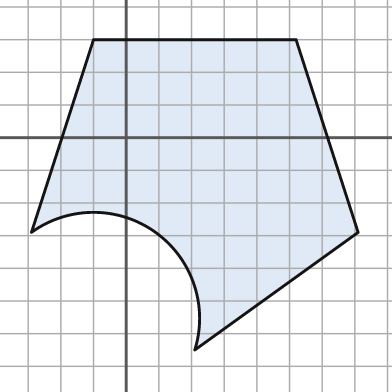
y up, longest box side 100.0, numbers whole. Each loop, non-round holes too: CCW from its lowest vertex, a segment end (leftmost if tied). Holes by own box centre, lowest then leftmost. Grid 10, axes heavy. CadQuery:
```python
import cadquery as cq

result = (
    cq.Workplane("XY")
    .moveTo(21.0, -65.0)
    .lineTo(71.0, -29.0)
    .lineTo(52.0, 30.0)
    .lineTo(-10.0, 30.0)
    .lineTo(-29.0, -29.0)
    .threePointArc((9.0, -29.0), (21.0, -65.0))
    .close()
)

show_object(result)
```